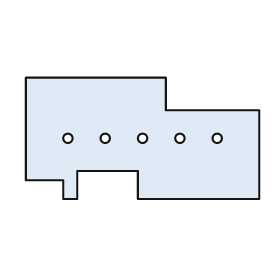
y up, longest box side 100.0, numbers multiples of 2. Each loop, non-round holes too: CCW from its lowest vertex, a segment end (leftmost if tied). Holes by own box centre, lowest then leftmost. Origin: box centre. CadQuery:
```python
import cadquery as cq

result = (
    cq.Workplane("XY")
    .moveTo(-34.0, -26.0)
    .lineTo(-28.0, -26.0)
    .lineTo(-28.0, -14.0)
    .lineTo(-2.0, -14.0)
    .lineTo(-2.0, -26.0)
    .lineTo(50.0, -26.0)
    .lineTo(50.0, 12.0)
    .lineTo(10.0, 12.0)
    .lineTo(10.0, 26.0)
    .lineTo(-50.0, 26.0)
    .lineTo(-50.0, -18.0)
    .lineTo(-34.0, -18.0)
    .close()
    .moveTo(-32.0, 0.0)
    .circle(2.0)
    .moveTo(-16.0, 0.0)
    .circle(2.0)
    .moveTo(0.0, 0.0)
    .circle(2.0)
    .moveTo(16.0, 0.0)
    .circle(2.0)
    .moveTo(32.0, 0.0)
    .circle(2.0)
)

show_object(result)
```